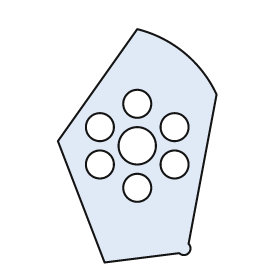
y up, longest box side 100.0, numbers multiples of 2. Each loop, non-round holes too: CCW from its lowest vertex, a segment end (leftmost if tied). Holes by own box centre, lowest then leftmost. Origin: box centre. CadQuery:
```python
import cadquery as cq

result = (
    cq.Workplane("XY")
    .moveTo(-14.0, -50.0)
    .lineTo(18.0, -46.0)
    .threePointArc((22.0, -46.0), (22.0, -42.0))
    .lineTo(34.0, 22.0)
    .threePointArc((20.0, 40.0), (0.0, 50.0))
    .lineTo(-34.0, 2.0)
    .close()
    .moveTo(0.0, -18.0)
    .circle(6.0)
    .moveTo(-16.0, -8.0)
    .circle(6.0)
    .moveTo(16.0, -8.0)
    .circle(6.0)
    .moveTo(0.0, 0.0)
    .circle(8.0)
    .moveTo(-16.0, 8.0)
    .circle(6.0)
    .moveTo(16.0, 8.0)
    .circle(6.0)
    .moveTo(0.0, 18.0)
    .circle(6.0)
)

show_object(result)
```